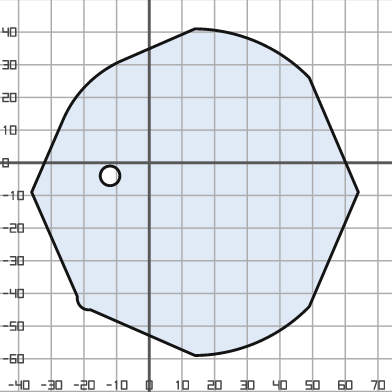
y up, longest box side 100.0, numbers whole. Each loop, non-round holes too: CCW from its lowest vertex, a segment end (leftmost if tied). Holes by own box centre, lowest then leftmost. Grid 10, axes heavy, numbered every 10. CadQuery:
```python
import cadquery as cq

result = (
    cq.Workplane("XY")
    .moveTo(14.0, -59.0)
    .threePointArc((33.0, -55.0), (49.0, -44.0))
    .lineTo(64.0, -9.0)
    .lineTo(49.0, 26.0)
    .threePointArc((33.0, 37.0), (14.0, 41.0))
    .lineTo(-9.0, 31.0)
    .threePointArc((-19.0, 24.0), (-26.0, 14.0))
    .lineTo(-36.0, -9.0)
    .lineTo(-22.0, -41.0)
    .threePointArc((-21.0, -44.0), (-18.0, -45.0))
    .close()
    .moveTo(-12.0, -4.0)
    .circle(3.0)
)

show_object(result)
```